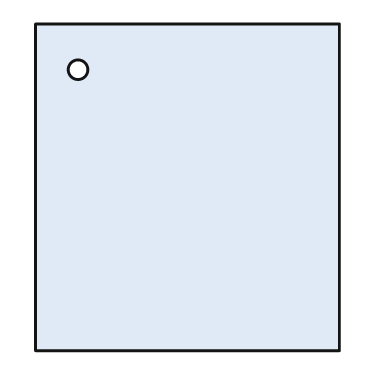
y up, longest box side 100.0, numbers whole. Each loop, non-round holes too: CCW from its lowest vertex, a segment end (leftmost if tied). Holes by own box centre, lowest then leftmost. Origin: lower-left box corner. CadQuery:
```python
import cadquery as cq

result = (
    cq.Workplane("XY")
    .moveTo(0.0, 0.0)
    .lineTo(93.0, 0.0)
    .lineTo(93.0, 100.0)
    .lineTo(0.0, 100.0)
    .close()
    .moveTo(13.0, 86.0)
    .circle(3.0)
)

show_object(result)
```